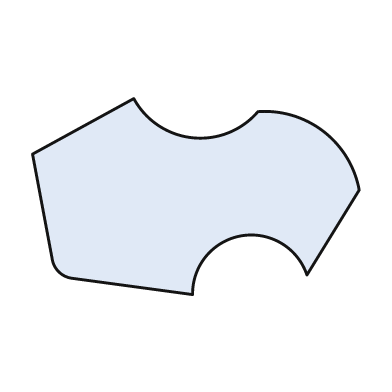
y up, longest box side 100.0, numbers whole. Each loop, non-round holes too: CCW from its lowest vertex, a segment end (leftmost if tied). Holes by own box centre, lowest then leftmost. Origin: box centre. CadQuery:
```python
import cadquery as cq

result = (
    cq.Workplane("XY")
    .moveTo(-1.0, -30.0)
    .threePointArc((14.0, -12.0), (34.0, -24.0))
    .lineTo(50.0, 2.0)
    .threePointArc((39.0, 20.0), (19.0, 26.0))
    .threePointArc((-1.0, 18.0), (-19.0, 30.0))
    .lineTo(-50.0, 13.0)
    .lineTo(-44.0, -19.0)
    .threePointArc((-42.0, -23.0), (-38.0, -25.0))
    .close()
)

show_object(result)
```